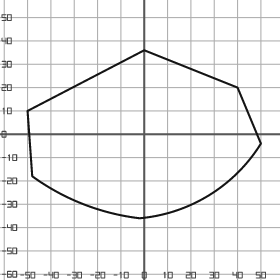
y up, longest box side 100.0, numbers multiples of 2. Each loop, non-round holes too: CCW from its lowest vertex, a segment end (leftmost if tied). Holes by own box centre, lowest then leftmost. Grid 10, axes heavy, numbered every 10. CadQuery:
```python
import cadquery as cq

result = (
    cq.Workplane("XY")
    .moveTo(-2.0, -36.0)
    .threePointArc((28.0, -26.0), (50.0, -4.0))
    .lineTo(40.0, 20.0)
    .lineTo(0.0, 36.0)
    .lineTo(-50.0, 10.0)
    .lineTo(-48.0, -18.0)
    .threePointArc((-26.0, -30.0), (-2.0, -36.0))
    .close()
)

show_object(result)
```